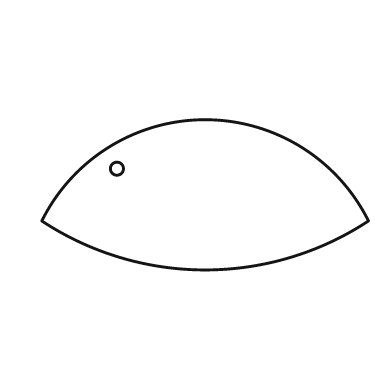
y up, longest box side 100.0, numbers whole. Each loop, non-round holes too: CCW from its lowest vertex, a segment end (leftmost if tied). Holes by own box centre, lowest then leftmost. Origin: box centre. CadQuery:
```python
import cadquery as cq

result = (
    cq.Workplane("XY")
    .moveTo(-50.0, -8.0)
    .threePointArc((0.0, -23.0), (50.0, -8.0))
    .threePointArc((0.0, 23.0), (-50.0, -8.0))
    .close()
    .moveTo(-27.0, 8.0)
    .circle(2.0)
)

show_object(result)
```